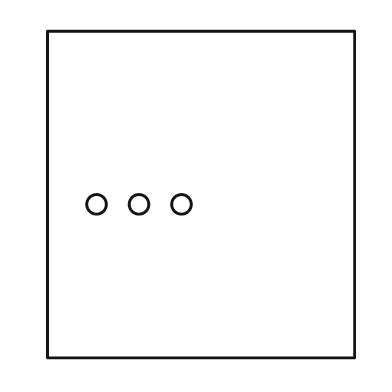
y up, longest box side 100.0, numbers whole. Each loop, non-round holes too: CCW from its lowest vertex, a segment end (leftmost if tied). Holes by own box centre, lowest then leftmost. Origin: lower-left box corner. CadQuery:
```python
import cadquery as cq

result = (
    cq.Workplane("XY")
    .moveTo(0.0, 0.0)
    .lineTo(94.0, 0.0)
    .lineTo(94.0, 100.0)
    .lineTo(0.0, 100.0)
    .close()
    .moveTo(15.0, 47.0)
    .circle(3.0)
    .moveTo(28.0, 47.0)
    .circle(3.0)
    .moveTo(41.0, 47.0)
    .circle(3.0)
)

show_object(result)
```